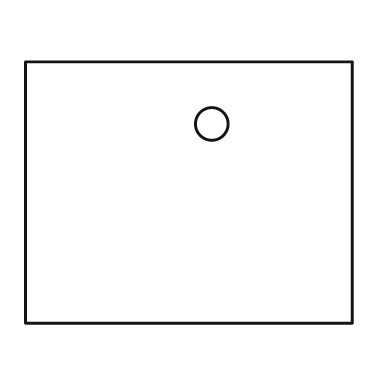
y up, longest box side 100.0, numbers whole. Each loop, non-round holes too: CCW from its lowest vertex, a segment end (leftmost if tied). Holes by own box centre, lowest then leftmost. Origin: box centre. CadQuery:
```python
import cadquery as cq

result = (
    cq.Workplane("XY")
    .moveTo(-50.0, -40.0)
    .lineTo(50.0, -40.0)
    .lineTo(50.0, 40.0)
    .lineTo(-50.0, 40.0)
    .close()
    .moveTo(7.0, 21.0)
    .circle(5.0)
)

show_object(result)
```